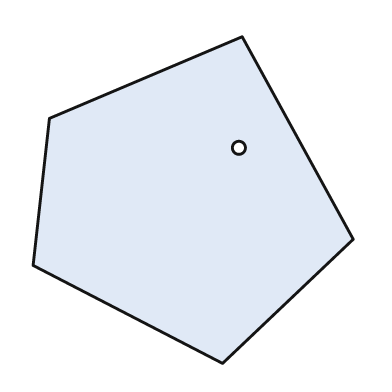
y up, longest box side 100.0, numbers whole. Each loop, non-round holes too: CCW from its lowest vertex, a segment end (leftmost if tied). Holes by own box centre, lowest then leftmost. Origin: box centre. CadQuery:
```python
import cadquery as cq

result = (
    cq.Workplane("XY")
    .moveTo(9.0, -50.0)
    .lineTo(49.0, -12.0)
    .lineTo(15.0, 50.0)
    .lineTo(-44.0, 25.0)
    .lineTo(-49.0, -20.0)
    .close()
    .moveTo(14.0, 16.0)
    .circle(2.0)
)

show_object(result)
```